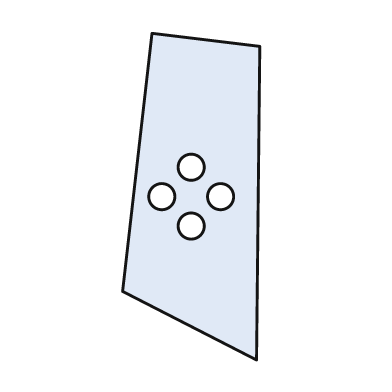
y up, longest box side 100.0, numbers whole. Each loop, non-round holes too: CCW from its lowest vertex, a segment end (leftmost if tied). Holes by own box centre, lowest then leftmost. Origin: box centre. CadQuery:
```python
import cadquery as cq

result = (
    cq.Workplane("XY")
    .moveTo(20.0, -50.0)
    .lineTo(21.0, 46.0)
    .lineTo(-12.0, 50.0)
    .lineTo(-21.0, -29.0)
    .close()
    .moveTo(0.0, -9.0)
    .circle(4.0)
    .moveTo(-9.0, 0.0)
    .circle(4.0)
    .moveTo(9.0, 0.0)
    .circle(4.0)
    .moveTo(0.0, 9.0)
    .circle(4.0)
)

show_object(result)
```